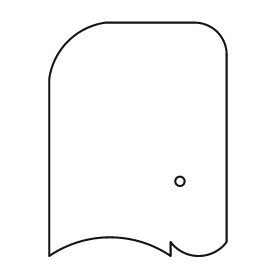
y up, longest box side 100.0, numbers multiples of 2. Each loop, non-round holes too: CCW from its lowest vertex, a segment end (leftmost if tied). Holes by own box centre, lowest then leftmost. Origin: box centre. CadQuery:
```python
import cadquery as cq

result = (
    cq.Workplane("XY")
    .moveTo(-38.0, -50.0)
    .threePointArc((-12.0, -42.0), (14.0, -50.0))
    .lineTo(14.0, -44.0)
    .threePointArc((26.0, -50.0), (38.0, -44.0))
    .lineTo(38.0, 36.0)
    .threePointArc((34.0, 46.0), (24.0, 50.0))
    .lineTo(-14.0, 50.0)
    .threePointArc((-30.0, 42.0), (-38.0, 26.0))
    .close()
    .moveTo(18.0, -18.0)
    .circle(2.0)
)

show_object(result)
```